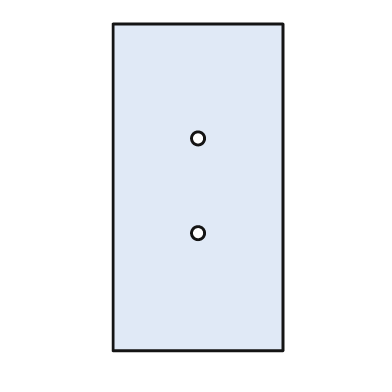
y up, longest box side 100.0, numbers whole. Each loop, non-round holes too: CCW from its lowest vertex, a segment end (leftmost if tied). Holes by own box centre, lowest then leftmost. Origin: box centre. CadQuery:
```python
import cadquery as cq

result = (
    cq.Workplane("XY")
    .moveTo(-26.0, -50.0)
    .lineTo(26.0, -50.0)
    .lineTo(26.0, 50.0)
    .lineTo(-26.0, 50.0)
    .close()
    .moveTo(0.0, -14.0)
    .circle(2.0)
    .moveTo(0.0, 15.0)
    .circle(2.0)
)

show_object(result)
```